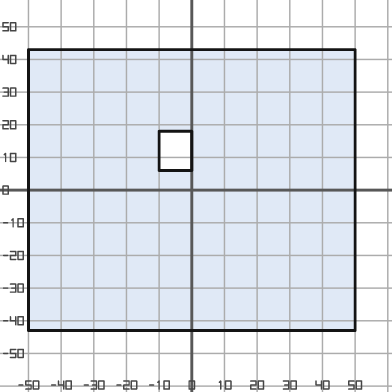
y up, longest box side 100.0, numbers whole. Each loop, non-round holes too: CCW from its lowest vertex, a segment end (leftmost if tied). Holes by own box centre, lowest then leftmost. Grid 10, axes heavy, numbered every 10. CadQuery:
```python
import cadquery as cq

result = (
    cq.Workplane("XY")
    .moveTo(-50.0, -43.0)
    .lineTo(50.0, -43.0)
    .lineTo(50.0, 43.0)
    .lineTo(-50.0, 43.0)
    .close()
    .moveTo(-10.0, 6.0)
    .lineTo(0.0, 6.0)
    .lineTo(0.0, 18.0)
    .lineTo(-10.0, 18.0)
    .close()
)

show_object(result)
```